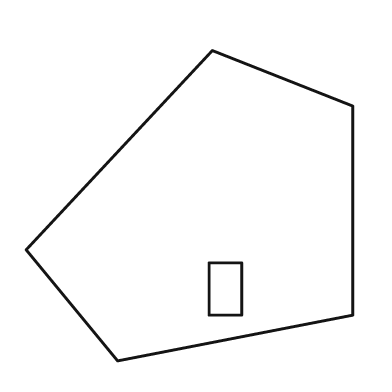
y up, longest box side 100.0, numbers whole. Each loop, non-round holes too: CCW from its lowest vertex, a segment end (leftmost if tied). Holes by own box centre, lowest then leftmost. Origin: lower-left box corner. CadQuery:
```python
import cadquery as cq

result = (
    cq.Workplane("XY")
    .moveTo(28.0, 0.0)
    .lineTo(100.0, 14.0)
    .lineTo(100.0, 78.0)
    .lineTo(57.0, 95.0)
    .lineTo(0.0, 34.0)
    .close()
    .moveTo(56.0, 14.0)
    .lineTo(66.0, 14.0)
    .lineTo(66.0, 30.0)
    .lineTo(56.0, 30.0)
    .close()
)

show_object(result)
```